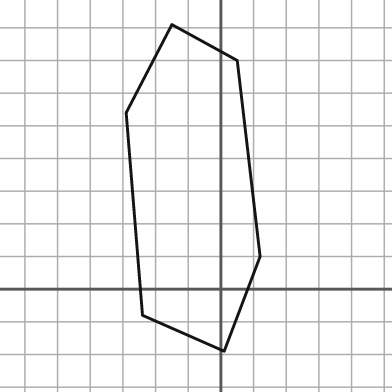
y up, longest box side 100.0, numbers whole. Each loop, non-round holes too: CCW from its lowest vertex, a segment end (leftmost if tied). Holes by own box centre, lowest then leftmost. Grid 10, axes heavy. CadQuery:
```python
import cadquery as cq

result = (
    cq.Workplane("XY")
    .moveTo(1.0, -19.0)
    .lineTo(12.0, 10.0)
    .lineTo(5.0, 70.0)
    .lineTo(-15.0, 81.0)
    .lineTo(-29.0, 54.0)
    .lineTo(-24.0, -8.0)
    .close()
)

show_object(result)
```